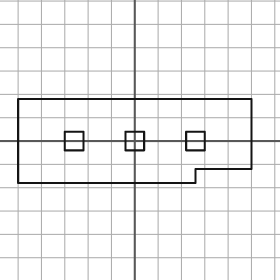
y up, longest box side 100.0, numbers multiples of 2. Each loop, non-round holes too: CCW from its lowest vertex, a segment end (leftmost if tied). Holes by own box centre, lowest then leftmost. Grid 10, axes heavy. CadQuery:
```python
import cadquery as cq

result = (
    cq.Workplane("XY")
    .moveTo(-50.0, -18.0)
    .lineTo(26.0, -18.0)
    .lineTo(26.0, -12.0)
    .lineTo(50.0, -12.0)
    .lineTo(50.0, 18.0)
    .lineTo(-50.0, 18.0)
    .close()
    .moveTo(-30.0, -4.0)
    .lineTo(-22.0, -4.0)
    .lineTo(-22.0, 4.0)
    .lineTo(-30.0, 4.0)
    .close()
    .moveTo(-4.0, -4.0)
    .lineTo(4.0, -4.0)
    .lineTo(4.0, 4.0)
    .lineTo(-4.0, 4.0)
    .close()
    .moveTo(22.0, -4.0)
    .lineTo(30.0, -4.0)
    .lineTo(30.0, 4.0)
    .lineTo(22.0, 4.0)
    .close()
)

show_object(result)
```